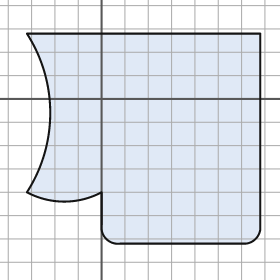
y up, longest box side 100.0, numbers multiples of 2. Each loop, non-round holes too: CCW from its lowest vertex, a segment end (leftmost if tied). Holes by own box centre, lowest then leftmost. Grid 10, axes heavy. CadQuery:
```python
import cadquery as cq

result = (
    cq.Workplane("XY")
    .moveTo(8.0, -62.0)
    .lineTo(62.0, -62.0)
    .threePointArc((66.0, -60.0), (68.0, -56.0))
    .lineTo(68.0, 28.0)
    .lineTo(-32.0, 28.0)
    .threePointArc((-22.0, -6.0), (-32.0, -40.0))
    .threePointArc((-16.0, -44.0), (0.0, -40.0))
    .lineTo(0.0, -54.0)
    .threePointArc((2.0, -60.0), (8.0, -62.0))
    .close()
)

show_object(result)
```